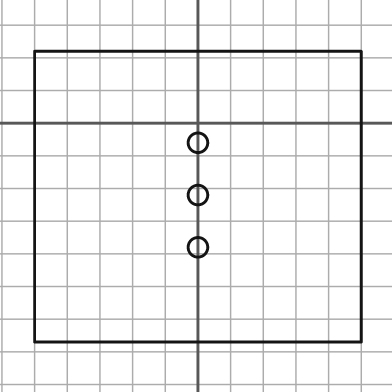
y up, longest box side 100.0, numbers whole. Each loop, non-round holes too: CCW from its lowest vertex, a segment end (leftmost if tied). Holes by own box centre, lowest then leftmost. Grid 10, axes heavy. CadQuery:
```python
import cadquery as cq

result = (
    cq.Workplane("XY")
    .moveTo(-50.0, -67.0)
    .lineTo(50.0, -67.0)
    .lineTo(50.0, 22.0)
    .lineTo(-50.0, 22.0)
    .close()
    .moveTo(0.0, -38.0)
    .circle(3.0)
    .moveTo(0.0, -22.0)
    .circle(3.0)
    .moveTo(0.0, -6.0)
    .circle(3.0)
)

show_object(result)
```